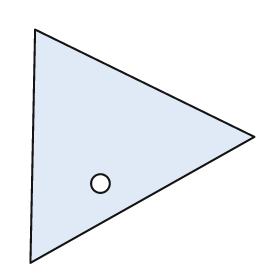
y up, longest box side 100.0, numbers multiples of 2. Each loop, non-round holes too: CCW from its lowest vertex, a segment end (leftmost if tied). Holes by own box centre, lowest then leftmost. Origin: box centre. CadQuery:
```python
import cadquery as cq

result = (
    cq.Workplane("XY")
    .moveTo(-48.0, -50.0)
    .lineTo(48.0, 4.0)
    .lineTo(-46.0, 50.0)
    .close()
    .moveTo(-18.0, -16.0)
    .circle(4.0)
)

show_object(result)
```